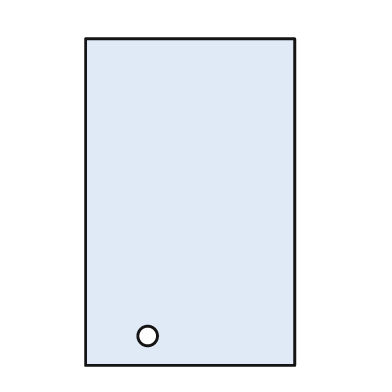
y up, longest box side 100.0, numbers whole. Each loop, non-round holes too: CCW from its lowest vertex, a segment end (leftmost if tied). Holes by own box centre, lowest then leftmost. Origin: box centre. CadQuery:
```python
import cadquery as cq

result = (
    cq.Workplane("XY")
    .moveTo(-32.0, -50.0)
    .lineTo(32.0, -50.0)
    .lineTo(32.0, 50.0)
    .lineTo(-32.0, 50.0)
    .close()
    .moveTo(-13.0, -41.0)
    .circle(3.0)
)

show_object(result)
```